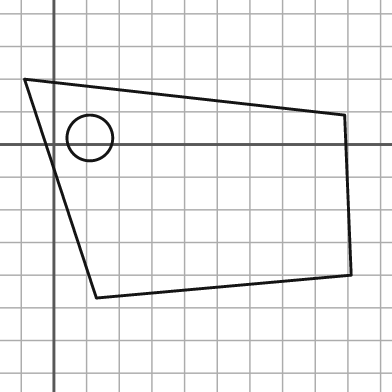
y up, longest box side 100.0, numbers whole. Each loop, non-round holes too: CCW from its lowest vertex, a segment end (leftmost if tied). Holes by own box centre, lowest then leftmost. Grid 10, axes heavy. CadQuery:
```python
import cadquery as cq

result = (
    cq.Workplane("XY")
    .moveTo(13.0, -47.0)
    .lineTo(91.0, -40.0)
    .lineTo(89.0, 9.0)
    .lineTo(-9.0, 20.0)
    .close()
    .moveTo(11.0, 2.0)
    .circle(7.0)
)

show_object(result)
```